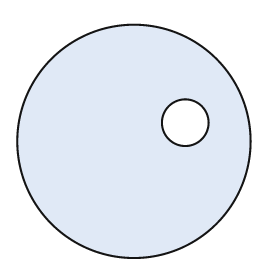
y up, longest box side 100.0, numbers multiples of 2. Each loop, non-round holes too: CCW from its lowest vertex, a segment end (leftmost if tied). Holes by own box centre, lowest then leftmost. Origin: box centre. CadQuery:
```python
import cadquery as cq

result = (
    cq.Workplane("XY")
    .moveTo(0.0, 0.0)
    .circle(50.0)
    .moveTo(22.0, 8.0)
    .circle(10.0)
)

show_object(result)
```